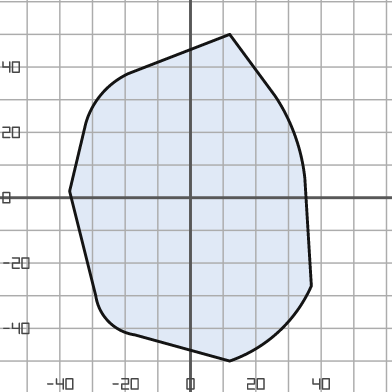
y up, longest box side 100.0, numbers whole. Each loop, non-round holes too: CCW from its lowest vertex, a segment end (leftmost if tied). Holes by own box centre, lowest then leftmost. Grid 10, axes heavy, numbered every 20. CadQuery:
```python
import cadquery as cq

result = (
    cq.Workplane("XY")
    .moveTo(12.0, -50.0)
    .threePointArc((27.0, -41.0), (37.0, -27.0))
    .lineTo(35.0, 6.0)
    .threePointArc((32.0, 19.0), (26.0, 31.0))
    .lineTo(12.0, 50.0)
    .lineTo(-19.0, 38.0)
    .threePointArc((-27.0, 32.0), (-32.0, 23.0))
    .lineTo(-37.0, 2.0)
    .lineTo(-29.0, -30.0)
    .threePointArc((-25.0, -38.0), (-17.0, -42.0))
    .close()
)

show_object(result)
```